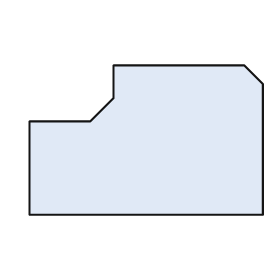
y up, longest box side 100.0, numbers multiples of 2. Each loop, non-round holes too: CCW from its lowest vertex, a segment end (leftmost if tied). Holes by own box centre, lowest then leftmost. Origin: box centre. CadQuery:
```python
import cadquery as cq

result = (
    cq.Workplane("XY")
    .moveTo(-50.0, -32.0)
    .lineTo(50.0, -32.0)
    .lineTo(50.0, 24.0)
    .lineTo(42.0, 32.0)
    .lineTo(-14.0, 32.0)
    .lineTo(-14.0, 18.0)
    .lineTo(-24.0, 8.0)
    .lineTo(-50.0, 8.0)
    .close()
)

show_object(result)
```